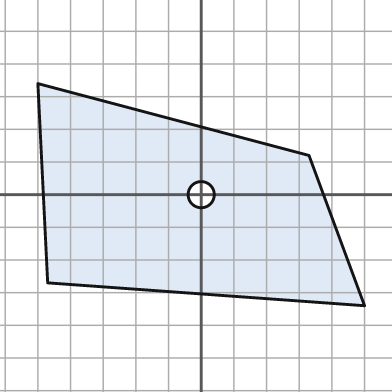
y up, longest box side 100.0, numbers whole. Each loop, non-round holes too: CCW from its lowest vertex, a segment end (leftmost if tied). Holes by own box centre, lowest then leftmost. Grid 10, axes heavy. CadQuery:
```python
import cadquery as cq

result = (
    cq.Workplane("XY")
    .moveTo(50.0, -34.0)
    .lineTo(33.0, 12.0)
    .lineTo(-50.0, 34.0)
    .lineTo(-47.0, -27.0)
    .close()
    .moveTo(0.0, 0.0)
    .circle(4.0)
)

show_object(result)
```